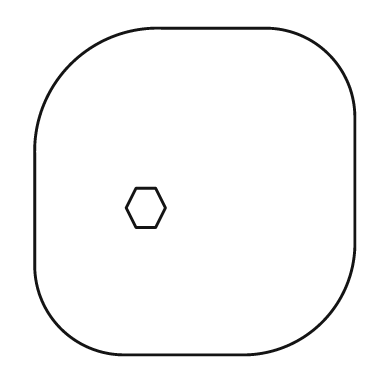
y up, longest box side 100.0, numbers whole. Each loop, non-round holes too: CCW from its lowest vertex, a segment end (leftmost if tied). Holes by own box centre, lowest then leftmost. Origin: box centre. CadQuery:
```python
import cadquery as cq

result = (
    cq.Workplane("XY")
    .moveTo(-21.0, -50.0)
    .lineTo(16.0, -50.0)
    .threePointArc((39.0, -40.0), (49.0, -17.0))
    .lineTo(49.0, 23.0)
    .threePointArc((41.0, 42.0), (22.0, 50.0))
    .lineTo(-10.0, 50.0)
    .threePointArc((-38.0, 39.0), (-49.0, 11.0))
    .lineTo(-49.0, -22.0)
    .threePointArc((-41.0, -42.0), (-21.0, -50.0))
    .close()
    .moveTo(-18.0, -11.0)
    .lineTo(-12.0, -11.0)
    .lineTo(-9.0, -5.0)
    .lineTo(-12.0, 1.0)
    .lineTo(-18.0, 1.0)
    .lineTo(-21.0, -5.0)
    .close()
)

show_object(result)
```